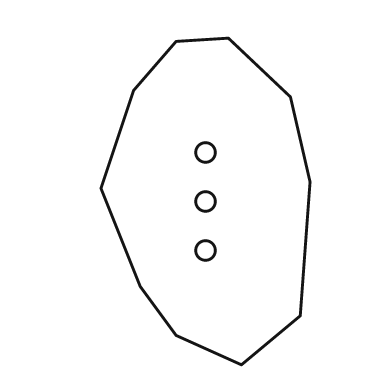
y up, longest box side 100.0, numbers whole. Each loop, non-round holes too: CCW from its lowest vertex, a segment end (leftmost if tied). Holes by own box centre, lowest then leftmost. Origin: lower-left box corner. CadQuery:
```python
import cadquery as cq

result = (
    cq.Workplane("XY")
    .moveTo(43.0, 0.0)
    .lineTo(61.0, 15.0)
    .lineTo(64.0, 56.0)
    .lineTo(58.0, 82.0)
    .lineTo(39.0, 100.0)
    .lineTo(23.0, 99.0)
    .lineTo(10.0, 84.0)
    .lineTo(0.0, 54.0)
    .lineTo(12.0, 24.0)
    .lineTo(23.0, 9.0)
    .close()
    .moveTo(32.0, 35.0)
    .circle(3.0)
    .moveTo(32.0, 50.0)
    .circle(3.0)
    .moveTo(32.0, 65.0)
    .circle(3.0)
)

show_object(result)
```